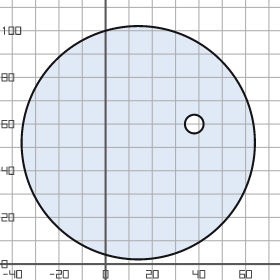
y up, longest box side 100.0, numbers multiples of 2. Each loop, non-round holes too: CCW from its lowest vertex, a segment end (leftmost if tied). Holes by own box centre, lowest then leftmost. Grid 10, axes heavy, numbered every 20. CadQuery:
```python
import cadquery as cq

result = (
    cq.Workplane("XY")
    .moveTo(14.0, 52.0)
    .circle(50.0)
    .moveTo(38.0, 60.0)
    .circle(4.0)
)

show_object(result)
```